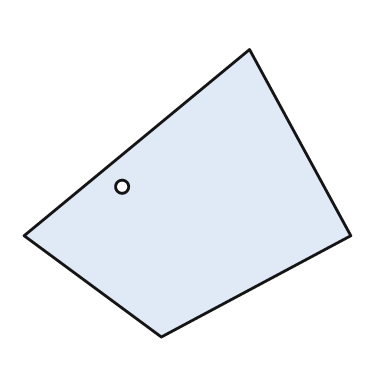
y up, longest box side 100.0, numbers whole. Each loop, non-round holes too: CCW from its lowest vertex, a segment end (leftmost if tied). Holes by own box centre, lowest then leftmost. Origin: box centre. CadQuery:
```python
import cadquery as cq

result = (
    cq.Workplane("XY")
    .moveTo(-8.0, -44.0)
    .lineTo(50.0, -13.0)
    .lineTo(19.0, 44.0)
    .lineTo(-50.0, -13.0)
    .close()
    .moveTo(-20.0, 2.0)
    .circle(2.0)
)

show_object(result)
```